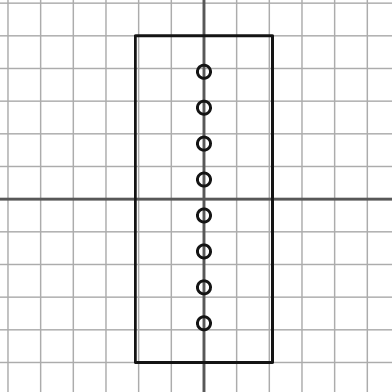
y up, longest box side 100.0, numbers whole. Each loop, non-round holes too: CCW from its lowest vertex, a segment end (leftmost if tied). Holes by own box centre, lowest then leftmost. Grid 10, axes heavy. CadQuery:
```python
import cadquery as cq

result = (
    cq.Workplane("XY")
    .moveTo(-21.0, -50.0)
    .lineTo(21.0, -50.0)
    .lineTo(21.0, 50.0)
    .lineTo(-21.0, 50.0)
    .close()
    .moveTo(0.0, -38.0)
    .circle(2.0)
    .moveTo(0.0, -27.0)
    .circle(2.0)
    .moveTo(0.0, -16.0)
    .circle(2.0)
    .moveTo(0.0, -5.0)
    .circle(2.0)
    .moveTo(0.0, 6.0)
    .circle(2.0)
    .moveTo(0.0, 17.0)
    .circle(2.0)
    .moveTo(0.0, 28.0)
    .circle(2.0)
    .moveTo(0.0, 39.0)
    .circle(2.0)
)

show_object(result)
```